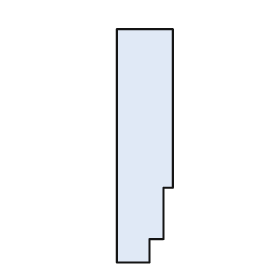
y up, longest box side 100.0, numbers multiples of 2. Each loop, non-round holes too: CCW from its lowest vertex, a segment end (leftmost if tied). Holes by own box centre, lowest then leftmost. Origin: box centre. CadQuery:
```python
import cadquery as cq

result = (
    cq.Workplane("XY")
    .moveTo(-12.0, -50.0)
    .lineTo(2.0, -50.0)
    .lineTo(2.0, -40.0)
    .lineTo(8.0, -40.0)
    .lineTo(8.0, -18.0)
    .lineTo(12.0, -18.0)
    .lineTo(12.0, 50.0)
    .lineTo(-12.0, 50.0)
    .close()
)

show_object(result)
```